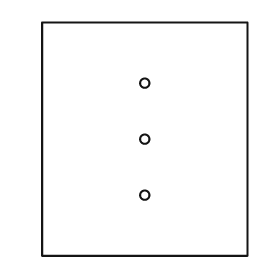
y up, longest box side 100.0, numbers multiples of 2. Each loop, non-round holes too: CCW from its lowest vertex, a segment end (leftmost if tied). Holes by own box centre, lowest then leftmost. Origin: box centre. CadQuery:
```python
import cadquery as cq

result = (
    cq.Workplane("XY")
    .moveTo(-44.0, -50.0)
    .lineTo(44.0, -50.0)
    .lineTo(44.0, 50.0)
    .lineTo(-44.0, 50.0)
    .close()
    .moveTo(0.0, -24.0)
    .circle(2.0)
    .moveTo(0.0, 0.0)
    .circle(2.0)
    .moveTo(0.0, 24.0)
    .circle(2.0)
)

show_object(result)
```